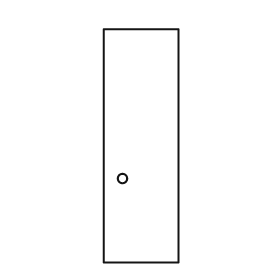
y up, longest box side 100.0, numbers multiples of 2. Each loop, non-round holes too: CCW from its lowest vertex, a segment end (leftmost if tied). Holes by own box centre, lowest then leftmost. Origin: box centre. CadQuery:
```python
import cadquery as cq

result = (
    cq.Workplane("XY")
    .moveTo(-16.0, -50.0)
    .lineTo(16.0, -50.0)
    .lineTo(16.0, 50.0)
    .lineTo(-16.0, 50.0)
    .close()
    .moveTo(-8.0, -14.0)
    .circle(2.0)
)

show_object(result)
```